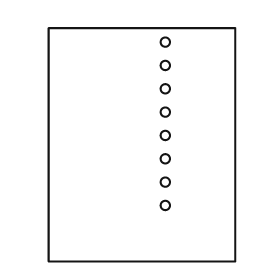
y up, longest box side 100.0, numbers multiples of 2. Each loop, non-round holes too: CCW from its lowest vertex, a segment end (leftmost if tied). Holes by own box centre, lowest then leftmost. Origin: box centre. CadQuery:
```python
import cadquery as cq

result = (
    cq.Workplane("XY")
    .moveTo(-40.0, -50.0)
    .lineTo(40.0, -50.0)
    .lineTo(40.0, 50.0)
    .lineTo(-40.0, 50.0)
    .close()
    .moveTo(10.0, -26.0)
    .circle(2.0)
    .moveTo(10.0, -16.0)
    .circle(2.0)
    .moveTo(10.0, -6.0)
    .circle(2.0)
    .moveTo(10.0, 4.0)
    .circle(2.0)
    .moveTo(10.0, 14.0)
    .circle(2.0)
    .moveTo(10.0, 24.0)
    .circle(2.0)
    .moveTo(10.0, 34.0)
    .circle(2.0)
    .moveTo(10.0, 44.0)
    .circle(2.0)
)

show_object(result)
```